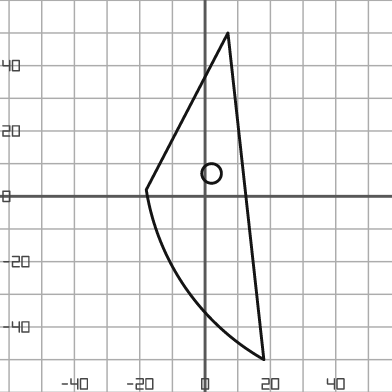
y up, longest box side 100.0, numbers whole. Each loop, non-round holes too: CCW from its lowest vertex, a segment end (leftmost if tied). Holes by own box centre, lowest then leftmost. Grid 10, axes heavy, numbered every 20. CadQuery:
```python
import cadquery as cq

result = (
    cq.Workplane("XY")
    .moveTo(18.0, -50.0)
    .lineTo(7.0, 50.0)
    .lineTo(-18.0, 2.0)
    .threePointArc((-6.0, -28.0), (18.0, -50.0))
    .close()
    .moveTo(2.0, 7.0)
    .circle(3.0)
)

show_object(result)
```